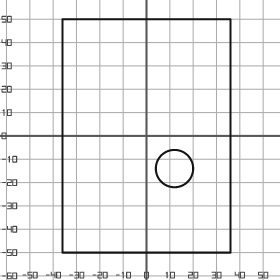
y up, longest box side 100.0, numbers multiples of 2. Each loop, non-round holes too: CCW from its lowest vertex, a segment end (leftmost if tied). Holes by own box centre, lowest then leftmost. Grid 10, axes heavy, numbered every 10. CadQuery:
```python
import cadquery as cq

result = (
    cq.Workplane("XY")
    .moveTo(-36.0, -50.0)
    .lineTo(36.0, -50.0)
    .lineTo(36.0, 50.0)
    .lineTo(-36.0, 50.0)
    .close()
    .moveTo(12.0, -14.0)
    .circle(8.0)
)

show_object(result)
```